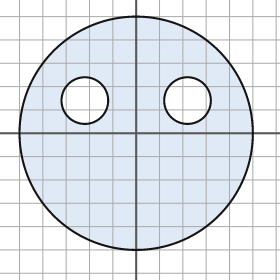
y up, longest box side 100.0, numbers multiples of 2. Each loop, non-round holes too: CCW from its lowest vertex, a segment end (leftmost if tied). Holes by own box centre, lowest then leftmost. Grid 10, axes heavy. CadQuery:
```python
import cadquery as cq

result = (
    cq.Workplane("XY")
    .moveTo(0.0, 0.0)
    .circle(50.0)
    .moveTo(-22.0, 14.0)
    .circle(10.0)
    .moveTo(22.0, 14.0)
    .circle(10.0)
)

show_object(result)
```